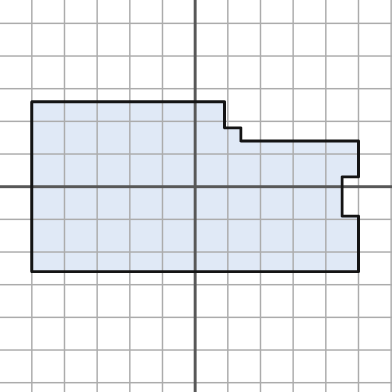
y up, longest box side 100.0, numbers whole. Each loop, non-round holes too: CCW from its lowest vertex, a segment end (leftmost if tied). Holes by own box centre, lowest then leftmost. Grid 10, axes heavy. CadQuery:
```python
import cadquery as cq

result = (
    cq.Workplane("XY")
    .moveTo(-50.0, -26.0)
    .lineTo(50.0, -26.0)
    .lineTo(50.0, -9.0)
    .lineTo(45.0, -9.0)
    .lineTo(45.0, 3.0)
    .lineTo(50.0, 3.0)
    .lineTo(50.0, 14.0)
    .lineTo(14.0, 14.0)
    .lineTo(14.0, 18.0)
    .lineTo(9.0, 18.0)
    .lineTo(9.0, 26.0)
    .lineTo(-50.0, 26.0)
    .close()
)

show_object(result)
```